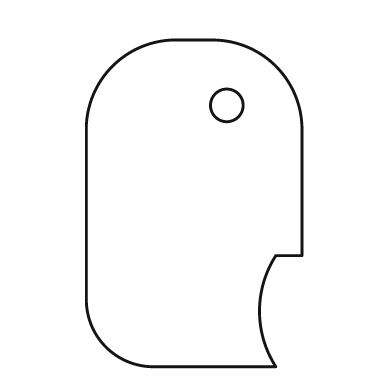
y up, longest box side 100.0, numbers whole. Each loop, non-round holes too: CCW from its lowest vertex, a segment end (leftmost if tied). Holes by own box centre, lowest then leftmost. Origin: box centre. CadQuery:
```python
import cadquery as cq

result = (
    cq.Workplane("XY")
    .moveTo(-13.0, -50.0)
    .lineTo(25.0, -50.0)
    .threePointArc((20.0, -33.0), (25.0, -16.0))
    .lineTo(33.0, -16.0)
    .lineTo(33.0, 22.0)
    .threePointArc((25.0, 42.0), (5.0, 50.0))
    .lineTo(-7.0, 50.0)
    .threePointArc((-25.0, 42.0), (-33.0, 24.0))
    .lineTo(-33.0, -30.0)
    .threePointArc((-27.0, -44.0), (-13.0, -50.0))
    .close()
    .moveTo(10.0, 30.0)
    .circle(5.0)
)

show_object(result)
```